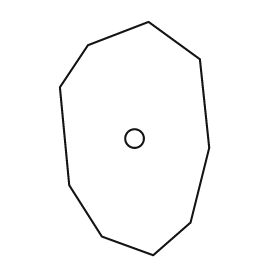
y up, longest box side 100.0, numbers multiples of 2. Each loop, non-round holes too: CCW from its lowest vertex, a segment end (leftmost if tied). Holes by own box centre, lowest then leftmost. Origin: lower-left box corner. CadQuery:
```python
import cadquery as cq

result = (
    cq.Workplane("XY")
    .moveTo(40.0, 0.0)
    .lineTo(56.0, 14.0)
    .lineTo(64.0, 46.0)
    .lineTo(60.0, 84.0)
    .lineTo(38.0, 100.0)
    .lineTo(12.0, 90.0)
    .lineTo(0.0, 72.0)
    .lineTo(4.0, 30.0)
    .lineTo(18.0, 8.0)
    .close()
    .moveTo(32.0, 50.0)
    .circle(4.0)
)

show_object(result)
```